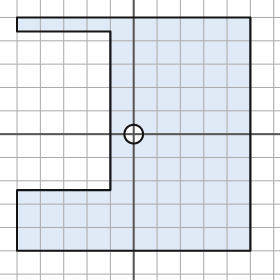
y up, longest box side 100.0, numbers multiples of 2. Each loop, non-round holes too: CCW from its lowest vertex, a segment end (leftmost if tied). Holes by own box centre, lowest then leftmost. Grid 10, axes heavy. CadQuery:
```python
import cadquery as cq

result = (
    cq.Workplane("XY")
    .moveTo(-50.0, -50.0)
    .lineTo(50.0, -50.0)
    .lineTo(50.0, 50.0)
    .lineTo(-50.0, 50.0)
    .lineTo(-50.0, 44.0)
    .lineTo(-10.0, 44.0)
    .lineTo(-10.0, -24.0)
    .lineTo(-50.0, -24.0)
    .close()
    .moveTo(0.0, 0.0)
    .circle(4.0)
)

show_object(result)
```